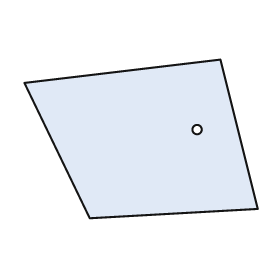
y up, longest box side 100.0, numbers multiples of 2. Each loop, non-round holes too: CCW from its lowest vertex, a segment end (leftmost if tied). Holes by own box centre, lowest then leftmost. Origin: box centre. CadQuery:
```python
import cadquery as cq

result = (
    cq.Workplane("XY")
    .moveTo(-22.0, -34.0)
    .lineTo(50.0, -30.0)
    .lineTo(34.0, 34.0)
    .lineTo(-50.0, 24.0)
    .close()
    .moveTo(24.0, 4.0)
    .circle(2.0)
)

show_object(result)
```